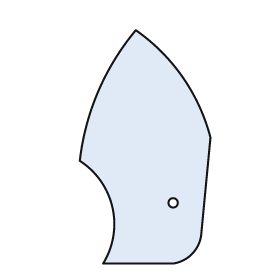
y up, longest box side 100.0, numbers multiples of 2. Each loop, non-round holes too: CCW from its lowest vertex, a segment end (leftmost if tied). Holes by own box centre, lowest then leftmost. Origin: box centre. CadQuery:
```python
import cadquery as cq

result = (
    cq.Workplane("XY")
    .moveTo(-18.0, -50.0)
    .lineTo(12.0, -50.0)
    .threePointArc((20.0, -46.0), (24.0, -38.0))
    .lineTo(28.0, 4.0)
    .threePointArc((16.0, 30.0), (-4.0, 50.0))
    .threePointArc((-20.0, 24.0), (-28.0, -6.0))
    .threePointArc((-14.0, -26.0), (-18.0, -50.0))
    .close()
    .moveTo(12.0, -24.0)
    .circle(2.0)
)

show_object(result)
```